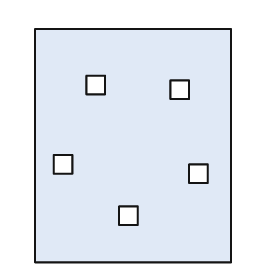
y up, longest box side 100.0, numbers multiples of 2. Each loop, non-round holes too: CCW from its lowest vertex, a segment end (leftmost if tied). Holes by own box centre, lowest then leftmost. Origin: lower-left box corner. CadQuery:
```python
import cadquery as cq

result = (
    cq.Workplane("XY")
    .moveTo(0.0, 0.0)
    .lineTo(84.0, 0.0)
    .lineTo(84.0, 100.0)
    .lineTo(0.0, 100.0)
    .close()
    .moveTo(36.0, 16.0)
    .lineTo(44.0, 16.0)
    .lineTo(44.0, 24.0)
    .lineTo(36.0, 24.0)
    .close()
    .moveTo(66.0, 34.0)
    .lineTo(74.0, 34.0)
    .lineTo(74.0, 42.0)
    .lineTo(66.0, 42.0)
    .close()
    .moveTo(8.0, 38.0)
    .lineTo(16.0, 38.0)
    .lineTo(16.0, 46.0)
    .lineTo(8.0, 46.0)
    .close()
    .moveTo(58.0, 70.0)
    .lineTo(66.0, 70.0)
    .lineTo(66.0, 78.0)
    .lineTo(58.0, 78.0)
    .close()
    .moveTo(22.0, 72.0)
    .lineTo(30.0, 72.0)
    .lineTo(30.0, 80.0)
    .lineTo(22.0, 80.0)
    .close()
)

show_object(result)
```